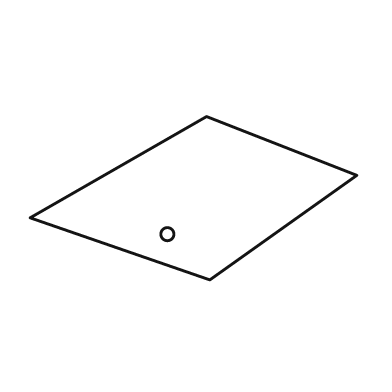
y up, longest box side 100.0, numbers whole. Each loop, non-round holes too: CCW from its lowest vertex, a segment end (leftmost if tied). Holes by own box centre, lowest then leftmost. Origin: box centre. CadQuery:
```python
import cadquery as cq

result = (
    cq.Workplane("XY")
    .moveTo(5.0, -25.0)
    .lineTo(50.0, 7.0)
    .lineTo(4.0, 25.0)
    .lineTo(-50.0, -6.0)
    .close()
    .moveTo(-8.0, -11.0)
    .circle(2.0)
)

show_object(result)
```